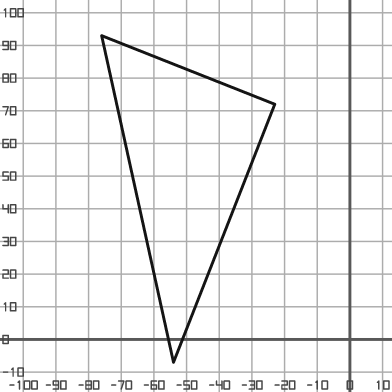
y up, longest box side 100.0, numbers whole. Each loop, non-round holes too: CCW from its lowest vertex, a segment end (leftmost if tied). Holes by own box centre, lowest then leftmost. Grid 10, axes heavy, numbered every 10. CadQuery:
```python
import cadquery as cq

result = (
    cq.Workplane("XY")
    .moveTo(-54.0, -7.0)
    .lineTo(-23.0, 72.0)
    .lineTo(-76.0, 93.0)
    .close()
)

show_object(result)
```